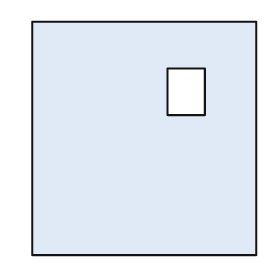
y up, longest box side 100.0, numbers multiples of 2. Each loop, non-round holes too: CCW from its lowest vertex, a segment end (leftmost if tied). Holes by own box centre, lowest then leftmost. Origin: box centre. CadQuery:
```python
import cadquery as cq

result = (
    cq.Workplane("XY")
    .moveTo(-48.0, -50.0)
    .lineTo(48.0, -50.0)
    .lineTo(48.0, 50.0)
    .lineTo(-48.0, 50.0)
    .close()
    .moveTo(10.0, 10.0)
    .lineTo(26.0, 10.0)
    .lineTo(26.0, 30.0)
    .lineTo(10.0, 30.0)
    .close()
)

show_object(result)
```